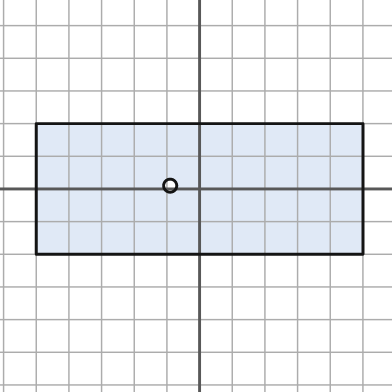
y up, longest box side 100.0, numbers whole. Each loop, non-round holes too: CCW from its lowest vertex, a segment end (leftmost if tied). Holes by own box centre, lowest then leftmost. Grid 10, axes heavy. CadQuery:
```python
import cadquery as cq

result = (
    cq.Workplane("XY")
    .moveTo(-50.0, -20.0)
    .lineTo(50.0, -20.0)
    .lineTo(50.0, 20.0)
    .lineTo(-50.0, 20.0)
    .close()
    .moveTo(-9.0, 1.0)
    .circle(2.0)
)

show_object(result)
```